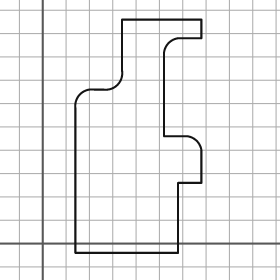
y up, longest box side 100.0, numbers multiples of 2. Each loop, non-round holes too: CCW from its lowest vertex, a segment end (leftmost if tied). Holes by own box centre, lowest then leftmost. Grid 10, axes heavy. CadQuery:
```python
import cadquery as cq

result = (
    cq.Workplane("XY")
    .moveTo(14.0, -4.0)
    .lineTo(58.0, -4.0)
    .lineTo(58.0, 26.0)
    .lineTo(68.0, 26.0)
    .lineTo(68.0, 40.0)
    .threePointArc((66.0, 44.0), (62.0, 46.0))
    .lineTo(52.0, 46.0)
    .lineTo(52.0, 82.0)
    .threePointArc((54.0, 86.0), (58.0, 88.0))
    .lineTo(68.0, 88.0)
    .lineTo(68.0, 96.0)
    .lineTo(34.0, 96.0)
    .lineTo(34.0, 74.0)
    .threePointArc((32.0, 68.0), (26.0, 66.0))
    .lineTo(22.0, 66.0)
    .threePointArc((16.0, 64.0), (14.0, 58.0))
    .close()
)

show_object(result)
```